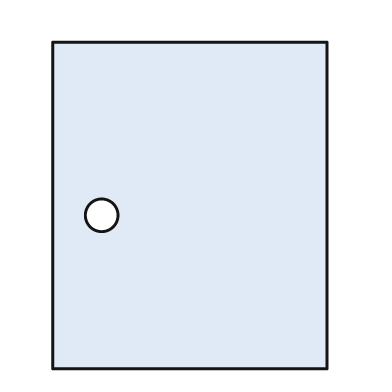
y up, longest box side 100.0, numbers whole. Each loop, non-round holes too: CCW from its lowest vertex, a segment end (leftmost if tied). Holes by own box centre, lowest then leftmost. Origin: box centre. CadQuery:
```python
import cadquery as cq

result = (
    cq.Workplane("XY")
    .moveTo(-42.0, -50.0)
    .lineTo(42.0, -50.0)
    .lineTo(42.0, 50.0)
    .lineTo(-42.0, 50.0)
    .close()
    .moveTo(-27.0, -3.0)
    .circle(5.0)
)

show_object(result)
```